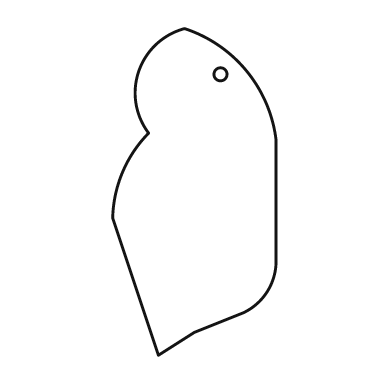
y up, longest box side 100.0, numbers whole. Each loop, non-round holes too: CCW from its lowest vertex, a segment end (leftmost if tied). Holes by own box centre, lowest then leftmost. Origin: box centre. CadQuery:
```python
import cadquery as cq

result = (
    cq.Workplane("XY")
    .moveTo(-11.0, -50.0)
    .lineTo(0.0, -43.0)
    .lineTo(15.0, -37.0)
    .threePointArc((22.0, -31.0), (25.0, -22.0))
    .lineTo(25.0, 16.0)
    .threePointArc((16.0, 37.0), (-3.0, 50.0))
    .threePointArc((-17.0, 37.0), (-14.0, 18.0))
    .threePointArc((-22.0, 6.0), (-25.0, -8.0))
    .close()
    .moveTo(8.0, 36.0)
    .circle(2.0)
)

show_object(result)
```